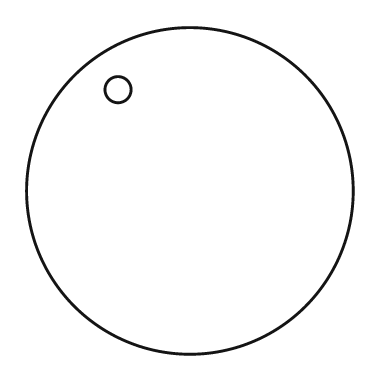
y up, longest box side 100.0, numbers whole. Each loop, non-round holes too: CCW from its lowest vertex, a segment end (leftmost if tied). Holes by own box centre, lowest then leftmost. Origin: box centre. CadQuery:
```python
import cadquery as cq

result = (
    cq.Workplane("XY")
    .moveTo(0.0, 0.0)
    .circle(50.0)
    .moveTo(-22.0, 31.0)
    .circle(4.0)
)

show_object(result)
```